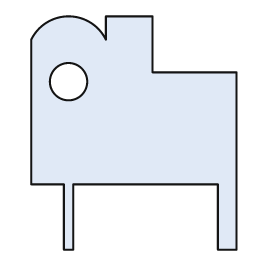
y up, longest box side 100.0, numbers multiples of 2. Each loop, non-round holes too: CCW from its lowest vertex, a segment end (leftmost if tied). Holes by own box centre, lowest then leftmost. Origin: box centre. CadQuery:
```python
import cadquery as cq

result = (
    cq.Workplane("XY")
    .moveTo(-30.0, -50.0)
    .lineTo(-26.0, -50.0)
    .lineTo(-26.0, -22.0)
    .lineTo(36.0, -22.0)
    .lineTo(36.0, -50.0)
    .lineTo(44.0, -50.0)
    .lineTo(44.0, 26.0)
    .lineTo(8.0, 26.0)
    .lineTo(8.0, 50.0)
    .lineTo(-12.0, 50.0)
    .lineTo(-12.0, 40.0)
    .threePointArc((-28.0, 50.0), (-44.0, 40.0))
    .lineTo(-44.0, -22.0)
    .lineTo(-30.0, -22.0)
    .close()
    .moveTo(-28.0, 22.0)
    .circle(8.0)
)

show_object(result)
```